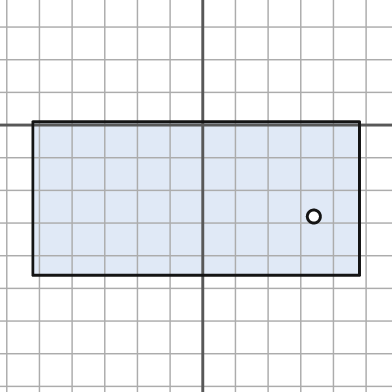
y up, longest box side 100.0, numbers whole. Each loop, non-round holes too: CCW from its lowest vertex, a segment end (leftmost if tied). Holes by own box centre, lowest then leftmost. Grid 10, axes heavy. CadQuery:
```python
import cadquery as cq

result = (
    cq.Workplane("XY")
    .moveTo(-52.0, -46.0)
    .lineTo(48.0, -46.0)
    .lineTo(48.0, 1.0)
    .lineTo(-52.0, 1.0)
    .close()
    .moveTo(34.0, -28.0)
    .circle(2.0)
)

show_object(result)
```